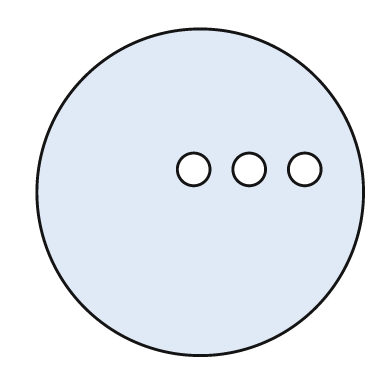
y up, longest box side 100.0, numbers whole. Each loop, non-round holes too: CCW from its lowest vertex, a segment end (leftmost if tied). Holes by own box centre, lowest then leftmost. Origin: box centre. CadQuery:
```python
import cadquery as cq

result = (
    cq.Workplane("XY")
    .moveTo(0.0, 0.0)
    .circle(50.0)
    .moveTo(-2.0, 7.0)
    .circle(5.0)
    .moveTo(15.0, 7.0)
    .circle(5.0)
    .moveTo(32.0, 7.0)
    .circle(5.0)
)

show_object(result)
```